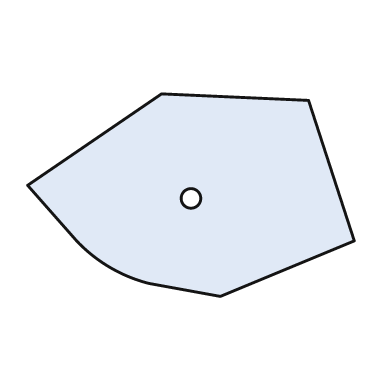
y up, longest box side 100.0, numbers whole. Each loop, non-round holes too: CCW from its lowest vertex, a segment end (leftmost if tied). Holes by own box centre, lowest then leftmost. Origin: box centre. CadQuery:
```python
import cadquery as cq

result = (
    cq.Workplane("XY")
    .moveTo(9.0, -31.0)
    .lineTo(50.0, -14.0)
    .lineTo(36.0, 29.0)
    .lineTo(-9.0, 31.0)
    .lineTo(-50.0, 3.0)
    .lineTo(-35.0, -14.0)
    .threePointArc((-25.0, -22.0), (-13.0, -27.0))
    .close()
    .moveTo(0.0, -1.0)
    .circle(3.0)
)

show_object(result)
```